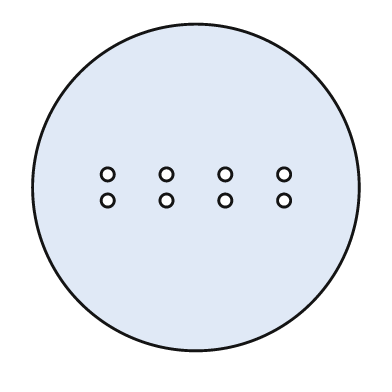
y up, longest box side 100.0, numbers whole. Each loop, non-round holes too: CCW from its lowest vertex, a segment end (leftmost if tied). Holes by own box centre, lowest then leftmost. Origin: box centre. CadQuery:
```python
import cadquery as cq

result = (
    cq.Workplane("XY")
    .moveTo(0.0, 0.0)
    .circle(50.0)
    .moveTo(-27.0, -4.0)
    .circle(2.0)
    .moveTo(-9.0, -4.0)
    .circle(2.0)
    .moveTo(9.0, -4.0)
    .circle(2.0)
    .moveTo(27.0, -4.0)
    .circle(2.0)
    .moveTo(-27.0, 4.0)
    .circle(2.0)
    .moveTo(-9.0, 4.0)
    .circle(2.0)
    .moveTo(9.0, 4.0)
    .circle(2.0)
    .moveTo(27.0, 4.0)
    .circle(2.0)
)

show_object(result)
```